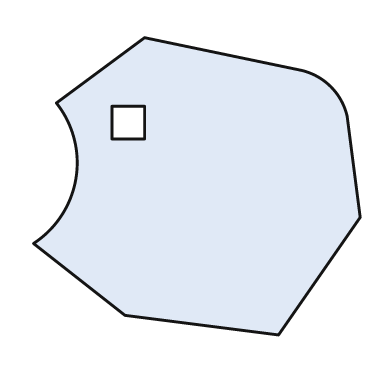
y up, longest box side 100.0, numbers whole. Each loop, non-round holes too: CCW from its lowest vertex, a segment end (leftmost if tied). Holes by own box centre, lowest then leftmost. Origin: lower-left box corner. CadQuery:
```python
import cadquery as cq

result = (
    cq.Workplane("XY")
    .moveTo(75.0, 0.0)
    .lineTo(100.0, 36.0)
    .lineTo(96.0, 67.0)
    .threePointArc((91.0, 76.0), (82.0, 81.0))
    .lineTo(34.0, 91.0)
    .lineTo(7.0, 71.0)
    .threePointArc((13.0, 48.0), (0.0, 28.0))
    .lineTo(28.0, 6.0)
    .close()
    .moveTo(24.0, 60.0)
    .lineTo(34.0, 60.0)
    .lineTo(34.0, 70.0)
    .lineTo(24.0, 70.0)
    .close()
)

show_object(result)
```